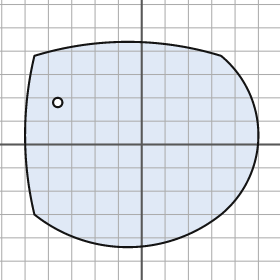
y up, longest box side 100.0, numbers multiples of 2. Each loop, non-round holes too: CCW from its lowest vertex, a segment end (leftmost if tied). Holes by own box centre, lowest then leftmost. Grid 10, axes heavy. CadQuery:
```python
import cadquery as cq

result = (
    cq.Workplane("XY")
    .moveTo(-46.0, -30.0)
    .threePointArc((-6.0, -44.0), (34.0, -30.0))
    .threePointArc((50.0, 4.0), (34.0, 38.0))
    .threePointArc((-6.0, 44.0), (-46.0, 38.0))
    .threePointArc((-50.0, 4.0), (-46.0, -30.0))
    .close()
    .moveTo(-36.0, 18.0)
    .circle(2.0)
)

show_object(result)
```